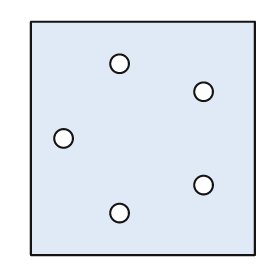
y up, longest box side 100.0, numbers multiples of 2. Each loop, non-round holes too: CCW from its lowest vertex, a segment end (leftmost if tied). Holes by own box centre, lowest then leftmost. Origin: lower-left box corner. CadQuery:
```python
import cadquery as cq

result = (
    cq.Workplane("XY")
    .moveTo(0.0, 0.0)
    .lineTo(96.0, 0.0)
    .lineTo(96.0, 100.0)
    .lineTo(0.0, 100.0)
    .close()
    .moveTo(38.0, 18.0)
    .circle(4.0)
    .moveTo(74.0, 30.0)
    .circle(4.0)
    .moveTo(14.0, 50.0)
    .circle(4.0)
    .moveTo(74.0, 70.0)
    .circle(4.0)
    .moveTo(38.0, 82.0)
    .circle(4.0)
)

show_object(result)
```